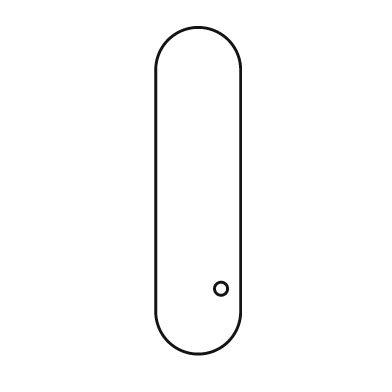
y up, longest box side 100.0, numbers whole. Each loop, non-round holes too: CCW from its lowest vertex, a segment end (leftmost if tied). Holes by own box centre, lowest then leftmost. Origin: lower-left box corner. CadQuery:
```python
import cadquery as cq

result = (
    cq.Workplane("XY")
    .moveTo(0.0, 13.0)
    .threePointArc((13.0, 0.0), (26.0, 13.0))
    .lineTo(26.0, 87.0)
    .threePointArc((13.0, 100.0), (0.0, 87.0))
    .close()
    .moveTo(20.0, 20.0)
    .circle(2.0)
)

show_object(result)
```